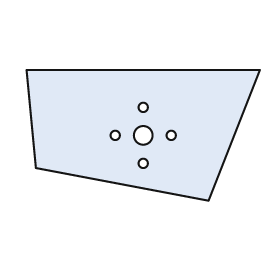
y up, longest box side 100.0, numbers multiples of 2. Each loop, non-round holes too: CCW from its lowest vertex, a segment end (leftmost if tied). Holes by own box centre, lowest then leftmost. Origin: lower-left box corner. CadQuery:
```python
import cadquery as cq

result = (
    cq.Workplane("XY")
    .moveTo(78.0, 0.0)
    .lineTo(100.0, 56.0)
    .lineTo(0.0, 56.0)
    .lineTo(4.0, 14.0)
    .close()
    .moveTo(50.0, 16.0)
    .circle(2.0)
    .moveTo(38.0, 28.0)
    .circle(2.0)
    .moveTo(50.0, 28.0)
    .circle(4.0)
    .moveTo(62.0, 28.0)
    .circle(2.0)
    .moveTo(50.0, 40.0)
    .circle(2.0)
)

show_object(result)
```